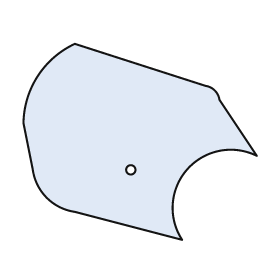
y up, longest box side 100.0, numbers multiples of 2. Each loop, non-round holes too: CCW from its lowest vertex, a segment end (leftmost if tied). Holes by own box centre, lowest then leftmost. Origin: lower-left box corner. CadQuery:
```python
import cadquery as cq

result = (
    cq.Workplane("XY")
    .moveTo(68.0, 0.0)
    .threePointArc((70.0, 30.0), (100.0, 36.0))
    .lineTo(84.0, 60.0)
    .threePointArc((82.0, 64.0), (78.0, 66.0))
    .lineTo(22.0, 84.0)
    .threePointArc((6.0, 70.0), (0.0, 50.0))
    .lineTo(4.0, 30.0)
    .threePointArc((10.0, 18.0), (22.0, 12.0))
    .close()
    .moveTo(46.0, 30.0)
    .circle(2.0)
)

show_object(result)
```